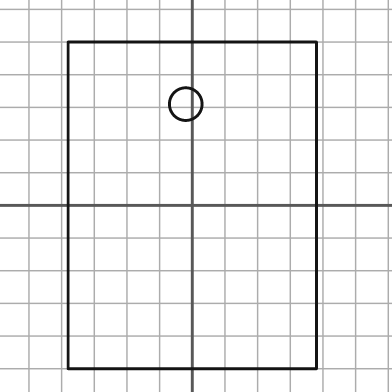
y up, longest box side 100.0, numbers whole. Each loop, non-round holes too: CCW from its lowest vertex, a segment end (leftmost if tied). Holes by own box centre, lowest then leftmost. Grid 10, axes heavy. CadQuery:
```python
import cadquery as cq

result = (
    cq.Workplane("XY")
    .moveTo(-38.0, -50.0)
    .lineTo(38.0, -50.0)
    .lineTo(38.0, 50.0)
    .lineTo(-38.0, 50.0)
    .close()
    .moveTo(-2.0, 31.0)
    .circle(5.0)
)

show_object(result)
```